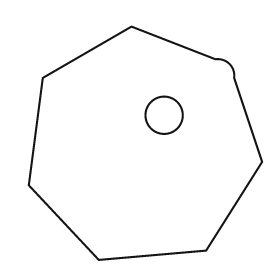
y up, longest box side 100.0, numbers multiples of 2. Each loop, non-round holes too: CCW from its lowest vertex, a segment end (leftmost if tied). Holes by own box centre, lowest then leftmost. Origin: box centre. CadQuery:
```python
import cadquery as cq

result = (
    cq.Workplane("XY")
    .moveTo(-20.0, -50.0)
    .lineTo(26.0, -46.0)
    .lineTo(50.0, -8.0)
    .lineTo(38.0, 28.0)
    .threePointArc((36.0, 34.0), (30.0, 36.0))
    .lineTo(-6.0, 50.0)
    .lineTo(-44.0, 28.0)
    .lineTo(-50.0, -18.0)
    .close()
    .moveTo(8.0, 12.0)
    .circle(8.0)
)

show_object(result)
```